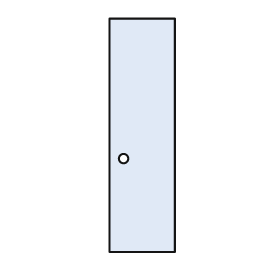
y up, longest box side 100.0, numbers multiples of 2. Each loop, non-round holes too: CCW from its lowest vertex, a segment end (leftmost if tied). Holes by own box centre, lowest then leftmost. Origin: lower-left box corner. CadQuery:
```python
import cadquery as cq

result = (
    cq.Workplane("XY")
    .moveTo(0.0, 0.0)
    .lineTo(28.0, 0.0)
    .lineTo(28.0, 100.0)
    .lineTo(0.0, 100.0)
    .close()
    .moveTo(6.0, 40.0)
    .circle(2.0)
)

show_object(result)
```